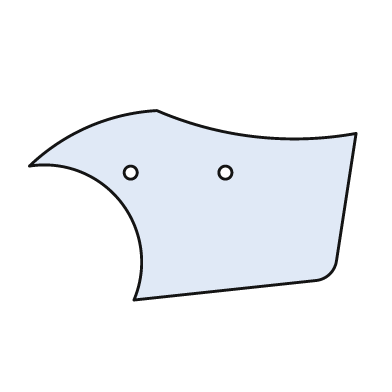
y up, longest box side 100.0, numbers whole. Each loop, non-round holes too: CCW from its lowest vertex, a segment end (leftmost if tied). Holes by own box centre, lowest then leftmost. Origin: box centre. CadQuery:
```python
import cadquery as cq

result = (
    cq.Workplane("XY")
    .moveTo(-18.0, -29.0)
    .lineTo(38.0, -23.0)
    .threePointArc((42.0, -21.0), (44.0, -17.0))
    .lineTo(50.0, 22.0)
    .threePointArc((19.0, 21.0), (-11.0, 29.0))
    .threePointArc((-32.0, 24.0), (-50.0, 12.0))
    .threePointArc((-22.0, 1.0), (-18.0, -29.0))
    .close()
    .moveTo(-19.0, 10.0)
    .circle(2.0)
    .moveTo(10.0, 10.0)
    .circle(2.0)
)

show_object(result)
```